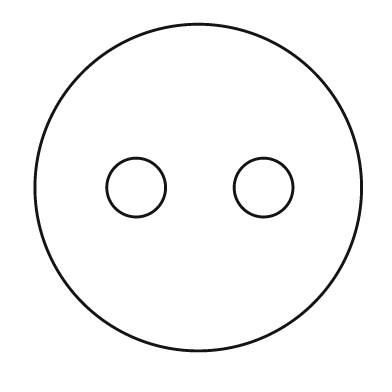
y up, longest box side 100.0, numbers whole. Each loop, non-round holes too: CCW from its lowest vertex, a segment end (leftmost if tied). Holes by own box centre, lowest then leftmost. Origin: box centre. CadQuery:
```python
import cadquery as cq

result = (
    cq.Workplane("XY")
    .moveTo(0.0, 0.0)
    .circle(50.0)
    .moveTo(-19.0, 0.0)
    .circle(9.0)
    .moveTo(20.0, 0.0)
    .circle(9.0)
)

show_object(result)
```